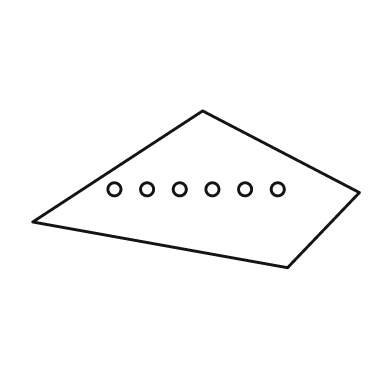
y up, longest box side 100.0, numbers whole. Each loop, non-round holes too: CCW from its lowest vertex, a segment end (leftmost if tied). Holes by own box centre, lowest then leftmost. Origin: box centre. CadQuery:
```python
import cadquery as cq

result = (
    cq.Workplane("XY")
    .moveTo(28.0, -24.0)
    .lineTo(50.0, -1.0)
    .lineTo(2.0, 24.0)
    .lineTo(-50.0, -10.0)
    .close()
    .moveTo(-25.0, 0.0)
    .circle(2.0)
    .moveTo(-15.0, 0.0)
    .circle(2.0)
    .moveTo(-5.0, 0.0)
    .circle(2.0)
    .moveTo(5.0, 0.0)
    .circle(2.0)
    .moveTo(15.0, 0.0)
    .circle(2.0)
    .moveTo(25.0, 0.0)
    .circle(2.0)
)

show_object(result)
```